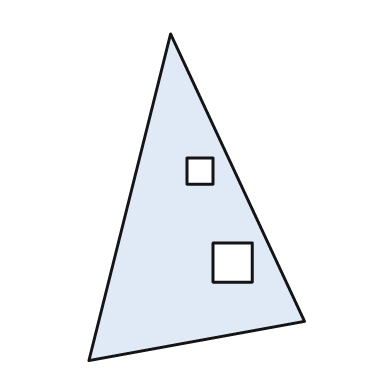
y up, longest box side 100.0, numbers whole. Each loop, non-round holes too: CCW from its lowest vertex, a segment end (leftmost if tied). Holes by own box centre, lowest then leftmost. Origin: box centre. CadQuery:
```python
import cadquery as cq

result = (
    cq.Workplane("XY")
    .moveTo(-33.0, -50.0)
    .lineTo(33.0, -38.0)
    .lineTo(-8.0, 50.0)
    .close()
    .moveTo(5.0, -26.0)
    .lineTo(17.0, -26.0)
    .lineTo(17.0, -14.0)
    .lineTo(5.0, -14.0)
    .close()
    .moveTo(-3.0, 4.0)
    .lineTo(5.0, 4.0)
    .lineTo(5.0, 12.0)
    .lineTo(-3.0, 12.0)
    .close()
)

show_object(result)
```